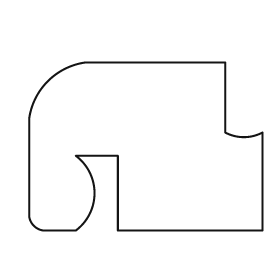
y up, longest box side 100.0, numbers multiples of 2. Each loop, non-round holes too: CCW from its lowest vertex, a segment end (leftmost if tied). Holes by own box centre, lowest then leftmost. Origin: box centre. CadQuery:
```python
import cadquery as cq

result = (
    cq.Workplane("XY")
    .moveTo(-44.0, -36.0)
    .lineTo(-30.0, -36.0)
    .threePointArc((-22.0, -20.0), (-30.0, -4.0))
    .lineTo(-12.0, -4.0)
    .lineTo(-12.0, -36.0)
    .lineTo(50.0, -36.0)
    .lineTo(50.0, 6.0)
    .threePointArc((42.0, 4.0), (34.0, 6.0))
    .lineTo(34.0, 36.0)
    .lineTo(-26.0, 36.0)
    .threePointArc((-42.0, 28.0), (-50.0, 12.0))
    .lineTo(-50.0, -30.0)
    .threePointArc((-48.0, -34.0), (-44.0, -36.0))
    .close()
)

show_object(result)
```